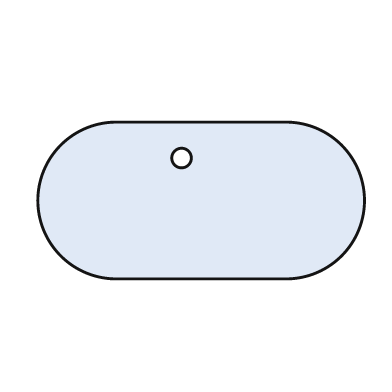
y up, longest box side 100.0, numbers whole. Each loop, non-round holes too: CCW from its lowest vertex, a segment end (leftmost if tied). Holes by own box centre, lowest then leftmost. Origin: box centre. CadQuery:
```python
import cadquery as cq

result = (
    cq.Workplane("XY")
    .moveTo(-26.0, -24.0)
    .lineTo(26.0, -24.0)
    .threePointArc((50.0, 0.0), (26.0, 24.0))
    .lineTo(-26.0, 24.0)
    .threePointArc((-50.0, 0.0), (-26.0, -24.0))
    .close()
    .moveTo(-6.0, 13.0)
    .circle(3.0)
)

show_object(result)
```